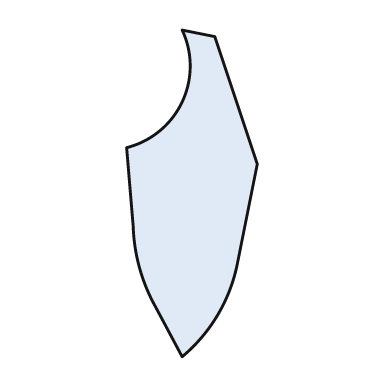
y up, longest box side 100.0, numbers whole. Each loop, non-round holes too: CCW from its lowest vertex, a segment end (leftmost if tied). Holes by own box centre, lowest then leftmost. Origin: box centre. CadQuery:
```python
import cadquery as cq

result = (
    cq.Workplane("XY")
    .moveTo(-3.0, -50.0)
    .threePointArc((8.0, -37.0), (14.0, -21.0))
    .lineTo(20.0, 9.0)
    .lineTo(7.0, 48.0)
    .lineTo(-3.0, 50.0)
    .threePointArc((-3.0, 28.0), (-20.0, 14.0))
    .lineTo(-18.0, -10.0)
    .threePointArc((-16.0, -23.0), (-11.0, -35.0))
    .close()
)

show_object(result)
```